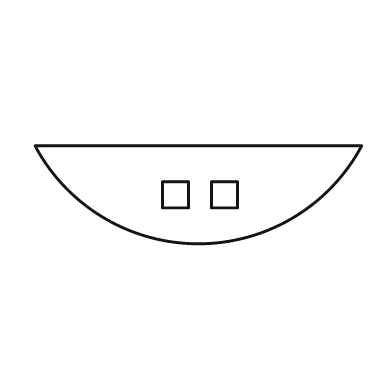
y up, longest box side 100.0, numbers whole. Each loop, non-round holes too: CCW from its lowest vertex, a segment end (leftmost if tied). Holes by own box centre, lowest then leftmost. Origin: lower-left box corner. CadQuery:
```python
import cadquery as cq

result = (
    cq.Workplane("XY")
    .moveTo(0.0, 30.0)
    .threePointArc((50.0, 0.0), (100.0, 30.0))
    .close()
    .moveTo(39.0, 11.0)
    .lineTo(47.0, 11.0)
    .lineTo(47.0, 19.0)
    .lineTo(39.0, 19.0)
    .close()
    .moveTo(54.0, 11.0)
    .lineTo(62.0, 11.0)
    .lineTo(62.0, 19.0)
    .lineTo(54.0, 19.0)
    .close()
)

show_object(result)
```